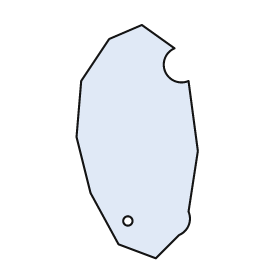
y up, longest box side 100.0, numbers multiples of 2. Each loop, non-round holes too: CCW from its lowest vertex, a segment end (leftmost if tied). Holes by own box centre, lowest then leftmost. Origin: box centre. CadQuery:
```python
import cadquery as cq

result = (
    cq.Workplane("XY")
    .moveTo(8.0, -50.0)
    .lineTo(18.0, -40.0)
    .threePointArc((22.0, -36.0), (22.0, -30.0))
    .lineTo(26.0, -4.0)
    .lineTo(22.0, 26.0)
    .threePointArc((12.0, 30.0), (16.0, 40.0))
    .lineTo(2.0, 50.0)
    .lineTo(-12.0, 44.0)
    .lineTo(-24.0, 26.0)
    .lineTo(-26.0, 2.0)
    .lineTo(-20.0, -22.0)
    .lineTo(-8.0, -44.0)
    .close()
    .moveTo(-4.0, -34.0)
    .circle(2.0)
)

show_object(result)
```